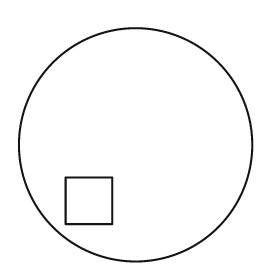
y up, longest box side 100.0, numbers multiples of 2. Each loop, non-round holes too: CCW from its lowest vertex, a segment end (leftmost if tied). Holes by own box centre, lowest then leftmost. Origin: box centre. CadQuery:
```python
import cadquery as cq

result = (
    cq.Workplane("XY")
    .moveTo(0.0, 0.0)
    .circle(50.0)
    .moveTo(-30.0, -34.0)
    .lineTo(-10.0, -34.0)
    .lineTo(-10.0, -14.0)
    .lineTo(-30.0, -14.0)
    .close()
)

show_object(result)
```